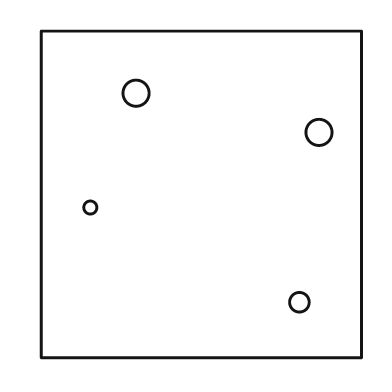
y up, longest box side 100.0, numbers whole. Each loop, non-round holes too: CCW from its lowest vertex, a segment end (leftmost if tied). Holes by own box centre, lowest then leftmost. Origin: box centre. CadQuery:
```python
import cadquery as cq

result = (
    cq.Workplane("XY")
    .moveTo(-49.0, -50.0)
    .lineTo(49.0, -50.0)
    .lineTo(49.0, 50.0)
    .lineTo(-49.0, 50.0)
    .close()
    .moveTo(30.0, -33.0)
    .circle(3.0)
    .moveTo(-34.0, -4.0)
    .circle(2.0)
    .moveTo(36.0, 19.0)
    .circle(4.0)
    .moveTo(-20.0, 31.0)
    .circle(4.0)
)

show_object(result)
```